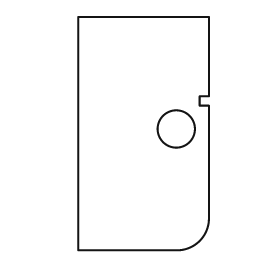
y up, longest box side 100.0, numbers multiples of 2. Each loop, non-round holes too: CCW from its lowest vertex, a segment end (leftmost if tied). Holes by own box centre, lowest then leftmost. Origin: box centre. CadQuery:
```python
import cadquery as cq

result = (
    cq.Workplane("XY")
    .moveTo(-28.0, -50.0)
    .lineTo(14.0, -50.0)
    .threePointArc((24.0, -46.0), (28.0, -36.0))
    .lineTo(28.0, 12.0)
    .lineTo(24.0, 12.0)
    .lineTo(24.0, 16.0)
    .lineTo(28.0, 16.0)
    .lineTo(28.0, 50.0)
    .lineTo(-28.0, 50.0)
    .close()
    .moveTo(14.0, 2.0)
    .circle(8.0)
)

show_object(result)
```